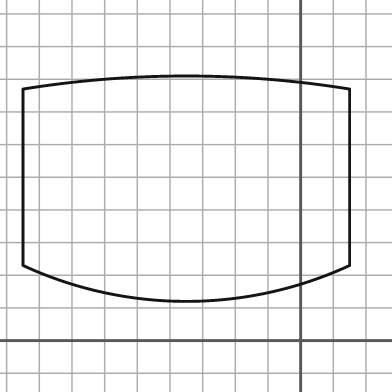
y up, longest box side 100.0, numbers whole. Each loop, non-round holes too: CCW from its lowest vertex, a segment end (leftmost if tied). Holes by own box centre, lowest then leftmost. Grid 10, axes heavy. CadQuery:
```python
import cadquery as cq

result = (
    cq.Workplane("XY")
    .moveTo(-85.0, 23.0)
    .threePointArc((-35.0, 12.0), (15.0, 23.0))
    .lineTo(15.0, 77.0)
    .threePointArc((-35.0, 81.0), (-85.0, 77.0))
    .close()
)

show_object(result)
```